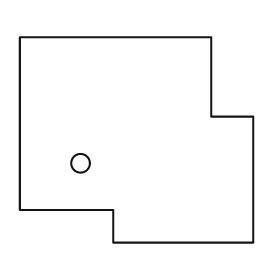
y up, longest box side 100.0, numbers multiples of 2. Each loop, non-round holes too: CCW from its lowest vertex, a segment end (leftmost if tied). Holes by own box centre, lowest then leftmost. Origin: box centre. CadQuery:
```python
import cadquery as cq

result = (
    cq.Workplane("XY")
    .moveTo(-10.0, -44.0)
    .lineTo(50.0, -44.0)
    .lineTo(50.0, 10.0)
    .lineTo(32.0, 10.0)
    .lineTo(32.0, 44.0)
    .lineTo(-50.0, 44.0)
    .lineTo(-50.0, -30.0)
    .lineTo(-10.0, -30.0)
    .close()
    .moveTo(-24.0, -10.0)
    .circle(4.0)
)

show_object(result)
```